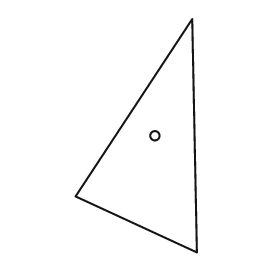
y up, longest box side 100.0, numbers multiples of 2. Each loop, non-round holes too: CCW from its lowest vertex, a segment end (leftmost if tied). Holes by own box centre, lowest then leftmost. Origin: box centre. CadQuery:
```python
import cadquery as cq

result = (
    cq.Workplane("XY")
    .moveTo(26.0, -50.0)
    .lineTo(24.0, 50.0)
    .lineTo(-26.0, -26.0)
    .close()
    .moveTo(8.0, 0.0)
    .circle(2.0)
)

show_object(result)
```